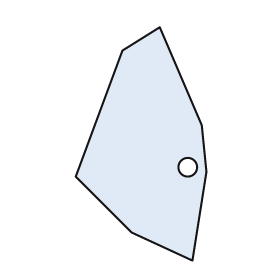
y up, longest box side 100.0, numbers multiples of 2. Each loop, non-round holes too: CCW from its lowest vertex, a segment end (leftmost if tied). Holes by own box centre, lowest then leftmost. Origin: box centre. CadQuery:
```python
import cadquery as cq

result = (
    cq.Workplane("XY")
    .moveTo(22.0, -50.0)
    .lineTo(28.0, -12.0)
    .lineTo(26.0, 8.0)
    .lineTo(8.0, 50.0)
    .lineTo(-8.0, 40.0)
    .lineTo(-28.0, -14.0)
    .lineTo(-4.0, -38.0)
    .close()
    .moveTo(20.0, -10.0)
    .circle(4.0)
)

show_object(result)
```